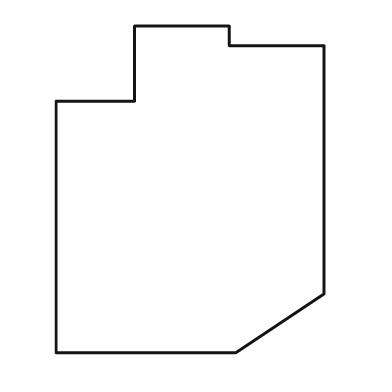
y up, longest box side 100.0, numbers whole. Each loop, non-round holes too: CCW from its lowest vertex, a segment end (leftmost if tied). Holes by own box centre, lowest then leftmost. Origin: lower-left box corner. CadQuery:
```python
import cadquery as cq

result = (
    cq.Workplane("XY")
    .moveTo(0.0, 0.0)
    .lineTo(55.0, 0.0)
    .lineTo(82.0, 18.0)
    .lineTo(82.0, 94.0)
    .lineTo(53.0, 94.0)
    .lineTo(53.0, 100.0)
    .lineTo(24.0, 100.0)
    .lineTo(24.0, 77.0)
    .lineTo(0.0, 77.0)
    .close()
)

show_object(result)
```